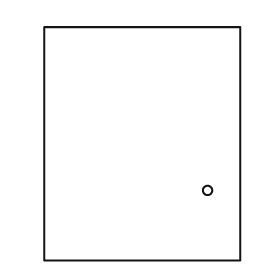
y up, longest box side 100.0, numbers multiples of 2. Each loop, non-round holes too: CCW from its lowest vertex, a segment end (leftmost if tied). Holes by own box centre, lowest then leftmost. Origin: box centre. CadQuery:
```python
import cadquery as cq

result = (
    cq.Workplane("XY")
    .moveTo(-42.0, -50.0)
    .lineTo(42.0, -50.0)
    .lineTo(42.0, 50.0)
    .lineTo(-42.0, 50.0)
    .close()
    .moveTo(28.0, -20.0)
    .circle(2.0)
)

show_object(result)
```